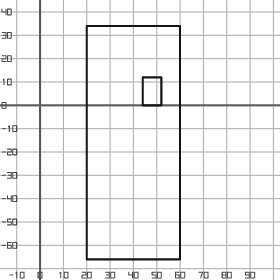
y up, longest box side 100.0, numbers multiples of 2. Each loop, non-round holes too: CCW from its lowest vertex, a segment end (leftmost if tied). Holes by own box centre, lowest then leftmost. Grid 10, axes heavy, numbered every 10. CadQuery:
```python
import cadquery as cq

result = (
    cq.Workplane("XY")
    .moveTo(20.0, -66.0)
    .lineTo(60.0, -66.0)
    .lineTo(60.0, 34.0)
    .lineTo(20.0, 34.0)
    .close()
    .moveTo(44.0, 0.0)
    .lineTo(52.0, 0.0)
    .lineTo(52.0, 12.0)
    .lineTo(44.0, 12.0)
    .close()
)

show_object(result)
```